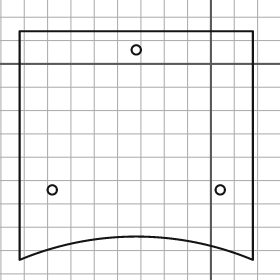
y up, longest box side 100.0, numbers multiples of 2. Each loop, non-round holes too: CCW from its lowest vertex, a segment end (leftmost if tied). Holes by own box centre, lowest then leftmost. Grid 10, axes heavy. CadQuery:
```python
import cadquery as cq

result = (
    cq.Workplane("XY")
    .moveTo(-82.0, -84.0)
    .threePointArc((-32.0, -74.0), (18.0, -84.0))
    .lineTo(18.0, 14.0)
    .lineTo(-82.0, 14.0)
    .close()
    .moveTo(-68.0, -54.0)
    .circle(2.0)
    .moveTo(4.0, -54.0)
    .circle(2.0)
    .moveTo(-32.0, 6.0)
    .circle(2.0)
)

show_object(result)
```